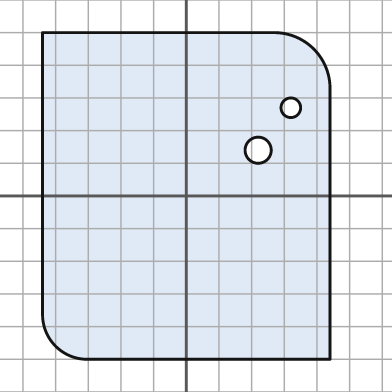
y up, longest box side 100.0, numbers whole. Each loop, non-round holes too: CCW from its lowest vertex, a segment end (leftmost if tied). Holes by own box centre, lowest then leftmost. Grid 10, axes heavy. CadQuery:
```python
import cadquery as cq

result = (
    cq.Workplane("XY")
    .moveTo(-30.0, -50.0)
    .lineTo(44.0, -50.0)
    .lineTo(44.0, 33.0)
    .threePointArc((39.0, 45.0), (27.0, 50.0))
    .lineTo(-44.0, 50.0)
    .lineTo(-44.0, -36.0)
    .threePointArc((-40.0, -46.0), (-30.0, -50.0))
    .close()
    .moveTo(22.0, 14.0)
    .circle(4.0)
    .moveTo(32.0, 27.0)
    .circle(3.0)
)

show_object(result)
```